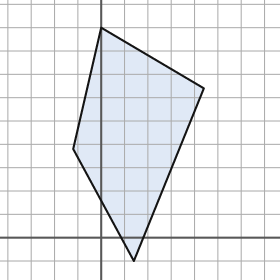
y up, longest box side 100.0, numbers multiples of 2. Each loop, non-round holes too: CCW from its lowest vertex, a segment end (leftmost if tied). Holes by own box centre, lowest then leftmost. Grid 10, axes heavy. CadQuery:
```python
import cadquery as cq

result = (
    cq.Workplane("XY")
    .moveTo(14.0, -10.0)
    .lineTo(44.0, 64.0)
    .lineTo(0.0, 90.0)
    .lineTo(-12.0, 38.0)
    .close()
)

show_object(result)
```